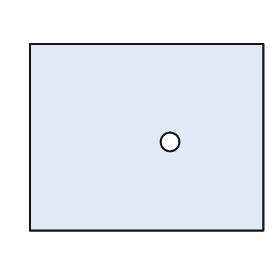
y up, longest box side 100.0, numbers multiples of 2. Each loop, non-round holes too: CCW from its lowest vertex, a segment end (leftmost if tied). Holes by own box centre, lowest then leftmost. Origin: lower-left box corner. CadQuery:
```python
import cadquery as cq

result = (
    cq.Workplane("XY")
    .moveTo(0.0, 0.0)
    .lineTo(100.0, 0.0)
    .lineTo(100.0, 80.0)
    .lineTo(0.0, 80.0)
    .close()
    .moveTo(60.0, 38.0)
    .circle(4.0)
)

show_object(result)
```